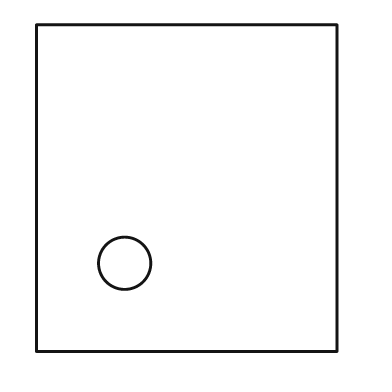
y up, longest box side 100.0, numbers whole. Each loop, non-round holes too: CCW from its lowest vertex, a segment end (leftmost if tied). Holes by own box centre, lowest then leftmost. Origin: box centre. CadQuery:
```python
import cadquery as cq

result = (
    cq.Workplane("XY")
    .moveTo(-46.0, -50.0)
    .lineTo(46.0, -50.0)
    .lineTo(46.0, 50.0)
    .lineTo(-46.0, 50.0)
    .close()
    .moveTo(-19.0, -23.0)
    .circle(8.0)
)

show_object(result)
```